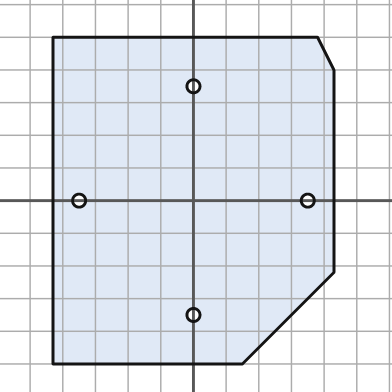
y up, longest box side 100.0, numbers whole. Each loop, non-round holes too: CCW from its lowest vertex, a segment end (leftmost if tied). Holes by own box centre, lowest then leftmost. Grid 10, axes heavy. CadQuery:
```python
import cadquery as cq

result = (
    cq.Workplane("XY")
    .moveTo(-43.0, -50.0)
    .lineTo(15.0, -50.0)
    .lineTo(43.0, -22.0)
    .lineTo(43.0, 40.0)
    .lineTo(38.0, 50.0)
    .lineTo(-43.0, 50.0)
    .close()
    .moveTo(0.0, -35.0)
    .circle(2.0)
    .moveTo(-35.0, 0.0)
    .circle(2.0)
    .moveTo(35.0, 0.0)
    .circle(2.0)
    .moveTo(0.0, 35.0)
    .circle(2.0)
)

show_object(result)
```